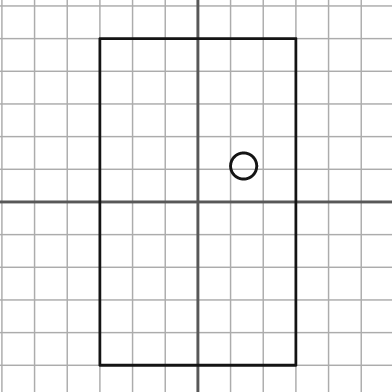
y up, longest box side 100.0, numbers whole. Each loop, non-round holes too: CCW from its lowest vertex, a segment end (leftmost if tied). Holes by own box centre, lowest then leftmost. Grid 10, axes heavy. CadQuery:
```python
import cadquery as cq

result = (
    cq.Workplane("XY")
    .moveTo(-30.0, -50.0)
    .lineTo(30.0, -50.0)
    .lineTo(30.0, 50.0)
    .lineTo(-30.0, 50.0)
    .close()
    .moveTo(14.0, 11.0)
    .circle(4.0)
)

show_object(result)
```